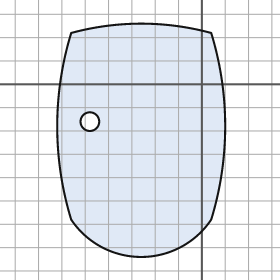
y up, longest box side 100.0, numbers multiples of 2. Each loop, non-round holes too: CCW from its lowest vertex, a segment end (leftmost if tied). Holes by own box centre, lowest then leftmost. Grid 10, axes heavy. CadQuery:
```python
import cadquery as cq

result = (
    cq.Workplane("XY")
    .moveTo(-56.0, -58.0)
    .threePointArc((-26.0, -74.0), (4.0, -58.0))
    .threePointArc((10.0, -18.0), (4.0, 22.0))
    .threePointArc((-26.0, 26.0), (-56.0, 22.0))
    .threePointArc((-62.0, -18.0), (-56.0, -58.0))
    .close()
    .moveTo(-48.0, -16.0)
    .circle(4.0)
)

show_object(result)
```